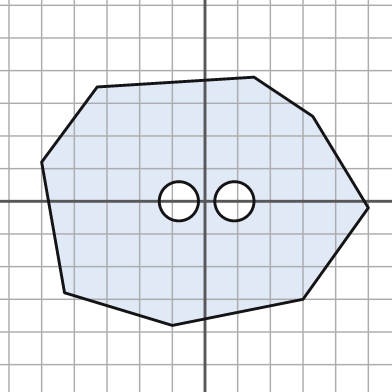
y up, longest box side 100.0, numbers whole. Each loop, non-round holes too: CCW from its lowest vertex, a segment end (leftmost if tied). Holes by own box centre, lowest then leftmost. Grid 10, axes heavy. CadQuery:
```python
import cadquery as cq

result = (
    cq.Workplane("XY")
    .moveTo(-10.0, -38.0)
    .lineTo(30.0, -30.0)
    .lineTo(50.0, -2.0)
    .lineTo(33.0, 26.0)
    .lineTo(15.0, 38.0)
    .lineTo(-33.0, 35.0)
    .lineTo(-50.0, 12.0)
    .lineTo(-43.0, -28.0)
    .close()
    .moveTo(-8.0, 0.0)
    .circle(6.0)
    .moveTo(9.0, 0.0)
    .circle(6.0)
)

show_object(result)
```